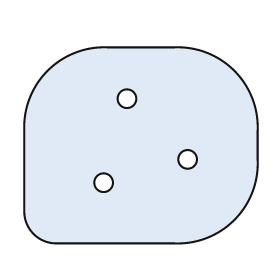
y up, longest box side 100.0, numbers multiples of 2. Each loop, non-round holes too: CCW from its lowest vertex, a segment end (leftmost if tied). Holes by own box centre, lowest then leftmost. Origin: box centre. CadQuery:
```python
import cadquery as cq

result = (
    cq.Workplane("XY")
    .moveTo(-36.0, -42.0)
    .lineTo(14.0, -42.0)
    .threePointArc((40.0, -32.0), (50.0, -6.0))
    .lineTo(50.0, 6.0)
    .threePointArc((40.0, 32.0), (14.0, 42.0))
    .lineTo(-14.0, 42.0)
    .threePointArc((-40.0, 32.0), (-50.0, 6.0))
    .lineTo(-50.0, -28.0)
    .threePointArc((-46.0, -38.0), (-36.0, -42.0))
    .close()
    .moveTo(-16.0, -16.0)
    .circle(4.0)
    .moveTo(20.0, -6.0)
    .circle(4.0)
    .moveTo(-6.0, 20.0)
    .circle(4.0)
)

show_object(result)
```